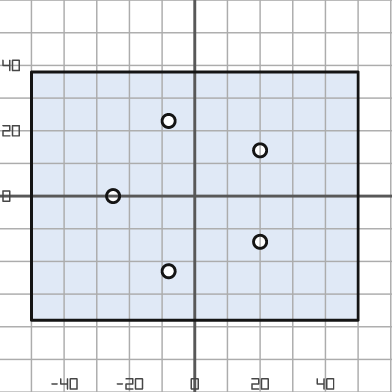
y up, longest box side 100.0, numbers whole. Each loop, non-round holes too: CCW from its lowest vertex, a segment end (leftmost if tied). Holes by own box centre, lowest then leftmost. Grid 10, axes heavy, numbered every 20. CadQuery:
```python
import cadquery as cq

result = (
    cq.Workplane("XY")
    .moveTo(-50.0, -38.0)
    .lineTo(50.0, -38.0)
    .lineTo(50.0, 38.0)
    .lineTo(-50.0, 38.0)
    .close()
    .moveTo(-8.0, -23.0)
    .circle(2.0)
    .moveTo(20.0, -14.0)
    .circle(2.0)
    .moveTo(-25.0, 0.0)
    .circle(2.0)
    .moveTo(20.0, 14.0)
    .circle(2.0)
    .moveTo(-8.0, 23.0)
    .circle(2.0)
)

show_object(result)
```